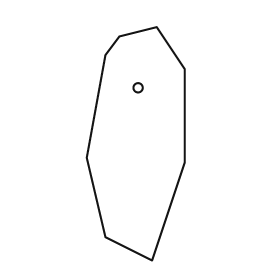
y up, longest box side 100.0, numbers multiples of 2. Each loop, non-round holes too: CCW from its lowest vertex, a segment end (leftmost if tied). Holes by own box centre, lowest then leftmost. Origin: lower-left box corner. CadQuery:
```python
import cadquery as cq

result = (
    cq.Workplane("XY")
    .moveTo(28.0, 0.0)
    .lineTo(42.0, 42.0)
    .lineTo(42.0, 82.0)
    .lineTo(30.0, 100.0)
    .lineTo(14.0, 96.0)
    .lineTo(8.0, 88.0)
    .lineTo(0.0, 44.0)
    .lineTo(8.0, 10.0)
    .close()
    .moveTo(22.0, 74.0)
    .circle(2.0)
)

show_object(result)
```